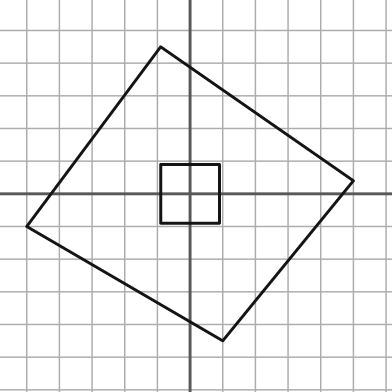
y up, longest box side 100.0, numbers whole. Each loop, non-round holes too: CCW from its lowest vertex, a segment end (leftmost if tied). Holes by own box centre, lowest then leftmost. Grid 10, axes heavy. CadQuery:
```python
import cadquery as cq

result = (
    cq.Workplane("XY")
    .moveTo(10.0, -45.0)
    .lineTo(50.0, 4.0)
    .lineTo(-9.0, 45.0)
    .lineTo(-50.0, -10.0)
    .close()
    .moveTo(-9.0, -9.0)
    .lineTo(9.0, -9.0)
    .lineTo(9.0, 9.0)
    .lineTo(-9.0, 9.0)
    .close()
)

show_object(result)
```